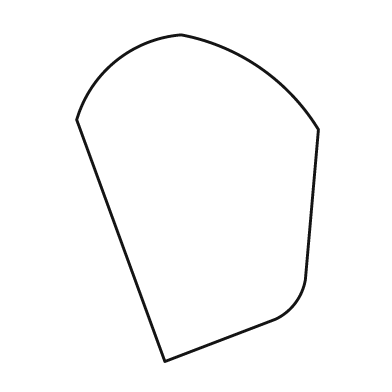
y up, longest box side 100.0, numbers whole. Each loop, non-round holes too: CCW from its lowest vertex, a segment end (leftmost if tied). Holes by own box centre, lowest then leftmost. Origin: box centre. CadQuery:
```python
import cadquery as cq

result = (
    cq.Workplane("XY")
    .moveTo(-10.0, -50.0)
    .lineTo(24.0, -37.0)
    .threePointArc((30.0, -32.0), (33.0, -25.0))
    .lineTo(37.0, 21.0)
    .threePointArc((19.0, 40.0), (-5.0, 50.0))
    .threePointArc((-25.0, 42.0), (-37.0, 24.0))
    .close()
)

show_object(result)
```